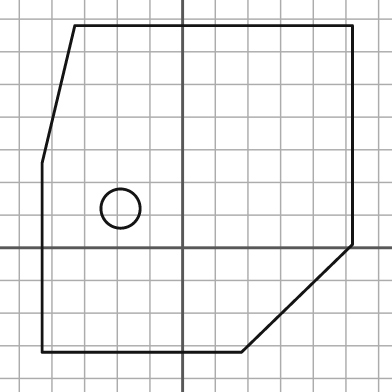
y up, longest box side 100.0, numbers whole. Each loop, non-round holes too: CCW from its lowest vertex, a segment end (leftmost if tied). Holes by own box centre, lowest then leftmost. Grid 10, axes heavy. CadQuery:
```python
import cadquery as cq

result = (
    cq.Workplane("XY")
    .moveTo(-43.0, -32.0)
    .lineTo(18.0, -32.0)
    .lineTo(52.0, 1.0)
    .lineTo(52.0, 68.0)
    .lineTo(-33.0, 68.0)
    .lineTo(-43.0, 26.0)
    .close()
    .moveTo(-19.0, 12.0)
    .circle(6.0)
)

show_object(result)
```